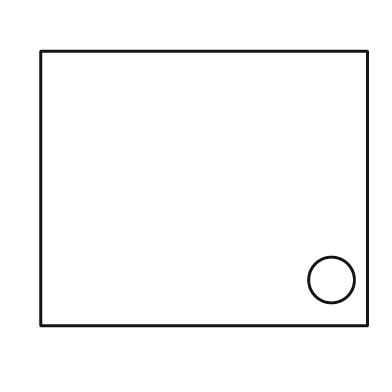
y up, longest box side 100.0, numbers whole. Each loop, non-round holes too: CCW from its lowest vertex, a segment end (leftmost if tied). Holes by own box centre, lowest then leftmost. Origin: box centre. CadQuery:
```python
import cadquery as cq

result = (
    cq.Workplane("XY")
    .moveTo(-50.0, -42.0)
    .lineTo(50.0, -42.0)
    .lineTo(50.0, 42.0)
    .lineTo(-50.0, 42.0)
    .close()
    .moveTo(39.0, -28.0)
    .circle(7.0)
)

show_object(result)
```